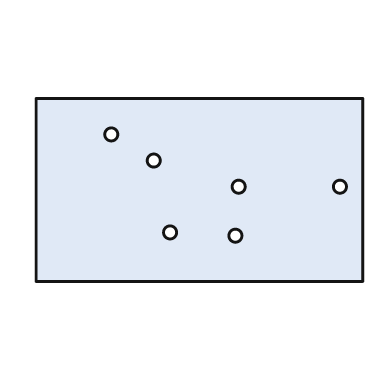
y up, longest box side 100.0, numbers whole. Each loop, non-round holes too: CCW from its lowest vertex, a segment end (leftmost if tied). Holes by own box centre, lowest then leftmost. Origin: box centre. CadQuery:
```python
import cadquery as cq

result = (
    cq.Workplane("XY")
    .moveTo(-50.0, -28.0)
    .lineTo(50.0, -28.0)
    .lineTo(50.0, 28.0)
    .lineTo(-50.0, 28.0)
    .close()
    .moveTo(11.0, -14.0)
    .circle(2.0)
    .moveTo(-9.0, -13.0)
    .circle(2.0)
    .moveTo(12.0, 1.0)
    .circle(2.0)
    .moveTo(43.0, 1.0)
    .circle(2.0)
    .moveTo(-14.0, 9.0)
    .circle(2.0)
    .moveTo(-27.0, 17.0)
    .circle(2.0)
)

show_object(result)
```